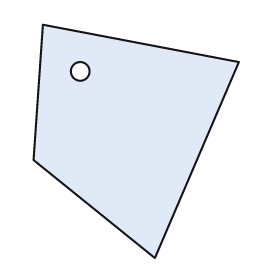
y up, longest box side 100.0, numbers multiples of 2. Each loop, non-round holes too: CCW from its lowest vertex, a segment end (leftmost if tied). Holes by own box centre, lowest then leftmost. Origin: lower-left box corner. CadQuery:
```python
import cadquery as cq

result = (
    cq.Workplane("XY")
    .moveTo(52.0, 0.0)
    .lineTo(88.0, 84.0)
    .lineTo(4.0, 100.0)
    .lineTo(0.0, 42.0)
    .close()
    .moveTo(20.0, 80.0)
    .circle(4.0)
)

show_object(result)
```